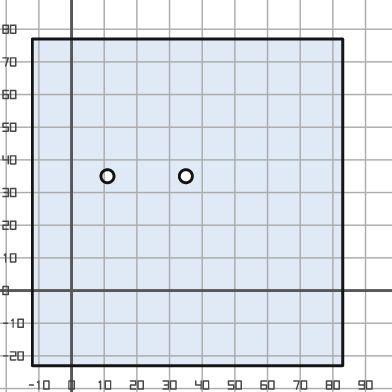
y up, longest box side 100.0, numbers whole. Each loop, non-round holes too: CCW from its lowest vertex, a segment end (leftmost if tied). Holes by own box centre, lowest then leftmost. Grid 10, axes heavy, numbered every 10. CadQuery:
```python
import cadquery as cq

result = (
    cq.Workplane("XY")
    .moveTo(-12.0, -23.0)
    .lineTo(83.0, -23.0)
    .lineTo(83.0, 77.0)
    .lineTo(-12.0, 77.0)
    .close()
    .moveTo(11.0, 35.0)
    .circle(2.0)
    .moveTo(35.0, 35.0)
    .circle(2.0)
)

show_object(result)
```